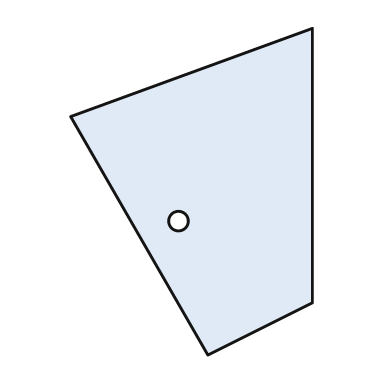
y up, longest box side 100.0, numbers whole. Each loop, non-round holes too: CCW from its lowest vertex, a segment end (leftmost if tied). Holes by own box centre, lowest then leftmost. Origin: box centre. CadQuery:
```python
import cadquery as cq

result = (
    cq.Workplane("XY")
    .moveTo(5.0, -50.0)
    .lineTo(37.0, -34.0)
    .lineTo(37.0, 50.0)
    .lineTo(-37.0, 23.0)
    .close()
    .moveTo(-4.0, -9.0)
    .circle(3.0)
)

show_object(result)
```